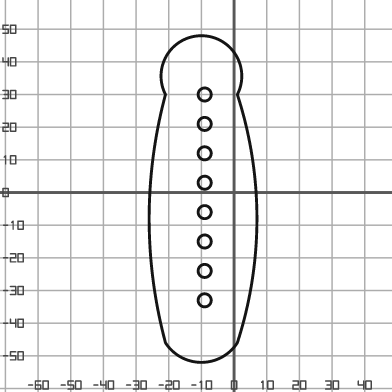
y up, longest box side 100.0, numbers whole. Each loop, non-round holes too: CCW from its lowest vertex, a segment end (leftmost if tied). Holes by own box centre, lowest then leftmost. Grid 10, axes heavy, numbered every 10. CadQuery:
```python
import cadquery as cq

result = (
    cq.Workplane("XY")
    .moveTo(-21.0, -46.0)
    .threePointArc((-10.0, -52.0), (1.0, -46.0))
    .threePointArc((7.0, -8.0), (1.0, 30.0))
    .threePointArc((-10.0, 48.0), (-21.0, 30.0))
    .threePointArc((-26.0, -8.0), (-21.0, -46.0))
    .close()
    .moveTo(-9.0, -33.0)
    .circle(2.0)
    .moveTo(-9.0, -24.0)
    .circle(2.0)
    .moveTo(-9.0, -15.0)
    .circle(2.0)
    .moveTo(-9.0, -6.0)
    .circle(2.0)
    .moveTo(-9.0, 3.0)
    .circle(2.0)
    .moveTo(-9.0, 12.0)
    .circle(2.0)
    .moveTo(-9.0, 21.0)
    .circle(2.0)
    .moveTo(-9.0, 30.0)
    .circle(2.0)
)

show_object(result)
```